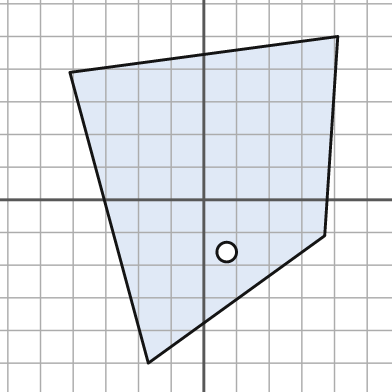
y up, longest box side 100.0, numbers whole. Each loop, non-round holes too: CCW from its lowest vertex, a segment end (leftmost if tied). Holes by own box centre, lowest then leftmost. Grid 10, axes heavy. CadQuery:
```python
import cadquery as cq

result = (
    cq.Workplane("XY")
    .moveTo(-17.0, -50.0)
    .lineTo(37.0, -11.0)
    .lineTo(41.0, 50.0)
    .lineTo(-41.0, 39.0)
    .close()
    .moveTo(7.0, -16.0)
    .circle(3.0)
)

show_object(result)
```